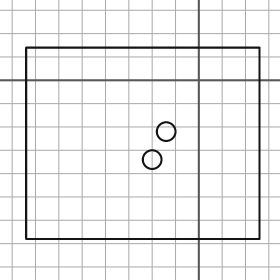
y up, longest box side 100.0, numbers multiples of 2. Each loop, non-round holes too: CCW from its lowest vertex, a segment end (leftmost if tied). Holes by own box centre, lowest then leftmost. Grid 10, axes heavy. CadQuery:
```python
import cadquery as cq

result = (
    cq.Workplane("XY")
    .moveTo(-74.0, -68.0)
    .lineTo(26.0, -68.0)
    .lineTo(26.0, 14.0)
    .lineTo(-74.0, 14.0)
    .close()
    .moveTo(-20.0, -34.0)
    .circle(4.0)
    .moveTo(-14.0, -22.0)
    .circle(4.0)
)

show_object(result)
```